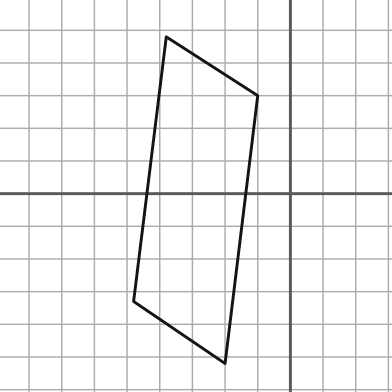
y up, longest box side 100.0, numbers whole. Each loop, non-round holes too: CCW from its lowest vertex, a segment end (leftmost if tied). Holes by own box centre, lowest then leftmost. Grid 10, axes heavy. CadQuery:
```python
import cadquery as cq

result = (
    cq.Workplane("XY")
    .moveTo(-20.0, -52.0)
    .lineTo(-10.0, 30.0)
    .lineTo(-38.0, 48.0)
    .lineTo(-48.0, -33.0)
    .close()
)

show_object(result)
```